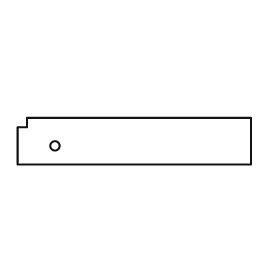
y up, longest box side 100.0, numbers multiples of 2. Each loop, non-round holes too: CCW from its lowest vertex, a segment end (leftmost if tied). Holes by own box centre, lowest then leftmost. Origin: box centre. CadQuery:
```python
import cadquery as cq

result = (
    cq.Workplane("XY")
    .moveTo(-50.0, -10.0)
    .lineTo(50.0, -10.0)
    .lineTo(50.0, 10.0)
    .lineTo(-46.0, 10.0)
    .lineTo(-46.0, 6.0)
    .lineTo(-50.0, 6.0)
    .close()
    .moveTo(-34.0, -2.0)
    .circle(2.0)
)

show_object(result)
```